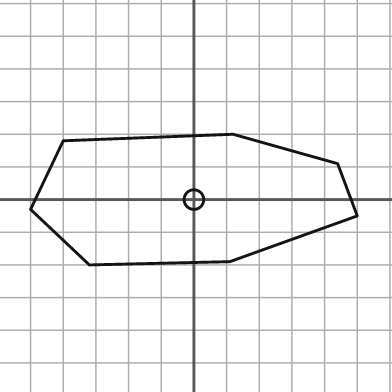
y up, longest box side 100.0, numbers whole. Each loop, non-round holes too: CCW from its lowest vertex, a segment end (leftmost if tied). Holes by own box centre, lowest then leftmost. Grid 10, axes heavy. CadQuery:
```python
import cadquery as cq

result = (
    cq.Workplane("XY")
    .moveTo(-32.0, -20.0)
    .lineTo(11.0, -19.0)
    .lineTo(50.0, -5.0)
    .lineTo(44.0, 11.0)
    .lineTo(12.0, 20.0)
    .lineTo(-40.0, 18.0)
    .lineTo(-50.0, -3.0)
    .close()
    .moveTo(0.0, 0.0)
    .circle(3.0)
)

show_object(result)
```